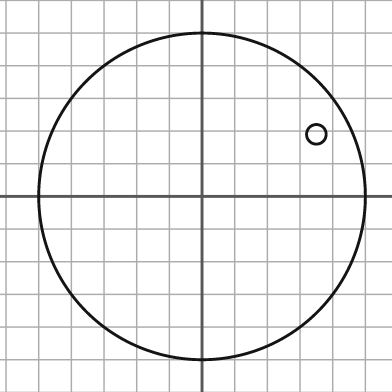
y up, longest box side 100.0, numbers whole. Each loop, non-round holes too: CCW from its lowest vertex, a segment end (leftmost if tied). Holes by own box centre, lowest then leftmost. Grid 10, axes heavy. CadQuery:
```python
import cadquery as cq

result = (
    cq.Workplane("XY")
    .moveTo(0.0, 0.0)
    .circle(50.0)
    .moveTo(35.0, 19.0)
    .circle(3.0)
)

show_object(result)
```